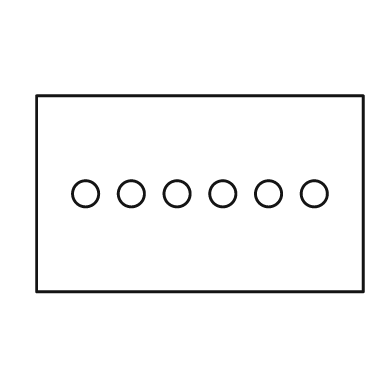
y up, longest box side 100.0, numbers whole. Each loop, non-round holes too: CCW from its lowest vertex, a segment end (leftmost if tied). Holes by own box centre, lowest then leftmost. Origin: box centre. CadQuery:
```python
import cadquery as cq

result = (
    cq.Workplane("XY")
    .moveTo(-50.0, -30.0)
    .lineTo(50.0, -30.0)
    .lineTo(50.0, 30.0)
    .lineTo(-50.0, 30.0)
    .close()
    .moveTo(-35.0, 0.0)
    .circle(4.0)
    .moveTo(-21.0, 0.0)
    .circle(4.0)
    .moveTo(-7.0, 0.0)
    .circle(4.0)
    .moveTo(7.0, 0.0)
    .circle(4.0)
    .moveTo(21.0, 0.0)
    .circle(4.0)
    .moveTo(35.0, 0.0)
    .circle(4.0)
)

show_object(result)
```